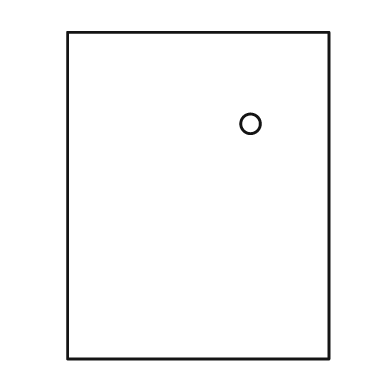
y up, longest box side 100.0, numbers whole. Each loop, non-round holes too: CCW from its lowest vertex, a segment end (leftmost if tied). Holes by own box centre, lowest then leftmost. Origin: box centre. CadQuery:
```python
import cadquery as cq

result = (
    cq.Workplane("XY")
    .moveTo(-40.0, -50.0)
    .lineTo(40.0, -50.0)
    .lineTo(40.0, 50.0)
    .lineTo(-40.0, 50.0)
    .close()
    .moveTo(16.0, 22.0)
    .circle(3.0)
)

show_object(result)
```